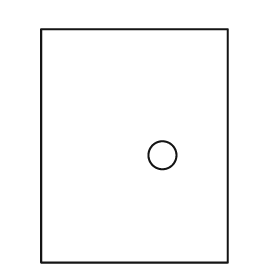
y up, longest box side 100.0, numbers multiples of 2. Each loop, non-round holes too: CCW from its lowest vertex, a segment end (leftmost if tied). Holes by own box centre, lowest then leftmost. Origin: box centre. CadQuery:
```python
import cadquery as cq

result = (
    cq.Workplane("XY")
    .moveTo(-40.0, -50.0)
    .lineTo(40.0, -50.0)
    .lineTo(40.0, 50.0)
    .lineTo(-40.0, 50.0)
    .close()
    .moveTo(12.0, -4.0)
    .circle(6.0)
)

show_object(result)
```